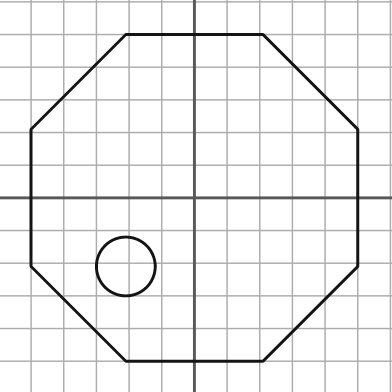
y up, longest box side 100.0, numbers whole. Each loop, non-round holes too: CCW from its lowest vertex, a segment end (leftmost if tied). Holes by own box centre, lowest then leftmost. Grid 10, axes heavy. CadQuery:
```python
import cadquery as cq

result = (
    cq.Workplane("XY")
    .moveTo(-21.0, -50.0)
    .lineTo(21.0, -50.0)
    .lineTo(50.0, -21.0)
    .lineTo(50.0, 21.0)
    .lineTo(21.0, 50.0)
    .lineTo(-21.0, 50.0)
    .lineTo(-50.0, 21.0)
    .lineTo(-50.0, -21.0)
    .close()
    .moveTo(-21.0, -21.0)
    .circle(9.0)
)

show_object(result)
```